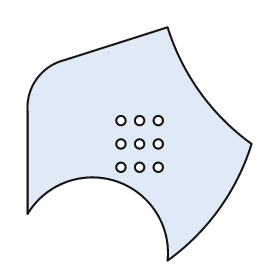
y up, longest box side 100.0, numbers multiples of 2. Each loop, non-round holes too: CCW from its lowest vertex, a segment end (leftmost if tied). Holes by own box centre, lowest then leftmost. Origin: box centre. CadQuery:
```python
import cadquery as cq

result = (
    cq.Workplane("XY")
    .moveTo(12.0, -50.0)
    .threePointArc((34.0, -28.0), (48.0, 0.0))
    .threePointArc((26.0, 22.0), (12.0, 50.0))
    .lineTo(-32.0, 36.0)
    .threePointArc((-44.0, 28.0), (-48.0, 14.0))
    .lineTo(-48.0, -30.0)
    .threePointArc((-10.0, -16.0), (12.0, -50.0))
    .close()
    .moveTo(-8.0, -10.0)
    .circle(2.0)
    .moveTo(0.0, -10.0)
    .circle(2.0)
    .moveTo(8.0, -10.0)
    .circle(2.0)
    .moveTo(-8.0, 0.0)
    .circle(2.0)
    .moveTo(0.0, 0.0)
    .circle(2.0)
    .moveTo(8.0, 0.0)
    .circle(2.0)
    .moveTo(-8.0, 10.0)
    .circle(2.0)
    .moveTo(0.0, 10.0)
    .circle(2.0)
    .moveTo(8.0, 10.0)
    .circle(2.0)
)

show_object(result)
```